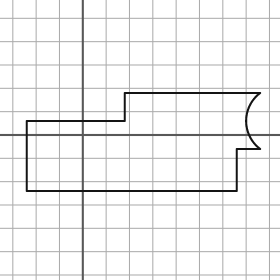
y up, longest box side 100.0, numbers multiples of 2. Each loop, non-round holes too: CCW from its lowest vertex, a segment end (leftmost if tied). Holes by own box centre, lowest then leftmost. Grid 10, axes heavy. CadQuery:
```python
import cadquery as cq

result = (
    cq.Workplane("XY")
    .moveTo(-24.0, -24.0)
    .lineTo(66.0, -24.0)
    .lineTo(66.0, -6.0)
    .lineTo(76.0, -6.0)
    .threePointArc((70.0, 6.0), (76.0, 18.0))
    .lineTo(18.0, 18.0)
    .lineTo(18.0, 6.0)
    .lineTo(-24.0, 6.0)
    .close()
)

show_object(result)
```